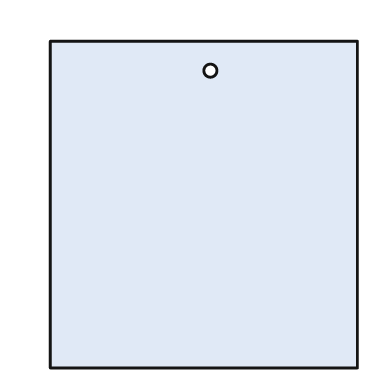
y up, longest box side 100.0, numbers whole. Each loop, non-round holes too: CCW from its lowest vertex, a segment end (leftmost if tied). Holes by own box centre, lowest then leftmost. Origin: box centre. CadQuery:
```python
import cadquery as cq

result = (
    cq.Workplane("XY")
    .moveTo(-47.0, -50.0)
    .lineTo(47.0, -50.0)
    .lineTo(47.0, 50.0)
    .lineTo(-47.0, 50.0)
    .close()
    .moveTo(2.0, 41.0)
    .circle(2.0)
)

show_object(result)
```